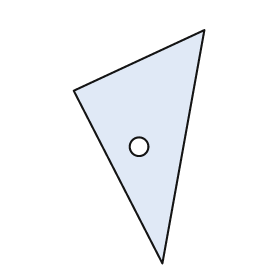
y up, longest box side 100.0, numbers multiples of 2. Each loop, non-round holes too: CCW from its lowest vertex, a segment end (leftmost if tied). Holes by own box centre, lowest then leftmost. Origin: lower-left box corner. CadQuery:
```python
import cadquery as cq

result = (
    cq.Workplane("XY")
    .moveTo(38.0, 0.0)
    .lineTo(56.0, 100.0)
    .lineTo(0.0, 74.0)
    .close()
    .moveTo(28.0, 50.0)
    .circle(4.0)
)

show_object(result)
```